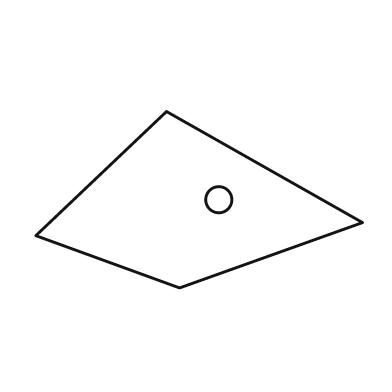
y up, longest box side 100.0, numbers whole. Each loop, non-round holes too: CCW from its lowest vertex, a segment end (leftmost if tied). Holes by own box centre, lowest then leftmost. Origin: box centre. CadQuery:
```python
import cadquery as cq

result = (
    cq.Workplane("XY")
    .moveTo(-6.0, -27.0)
    .lineTo(50.0, -7.0)
    .lineTo(-10.0, 27.0)
    .lineTo(-50.0, -11.0)
    .close()
    .moveTo(6.0, 0.0)
    .circle(4.0)
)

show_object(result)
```